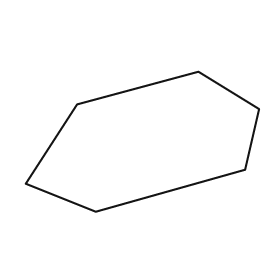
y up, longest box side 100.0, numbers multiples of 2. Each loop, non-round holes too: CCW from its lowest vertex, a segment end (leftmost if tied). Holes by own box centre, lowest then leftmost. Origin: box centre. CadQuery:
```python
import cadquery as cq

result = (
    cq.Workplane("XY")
    .moveTo(-20.0, -30.0)
    .lineTo(44.0, -12.0)
    .lineTo(50.0, 14.0)
    .lineTo(24.0, 30.0)
    .lineTo(-28.0, 16.0)
    .lineTo(-50.0, -18.0)
    .close()
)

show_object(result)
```